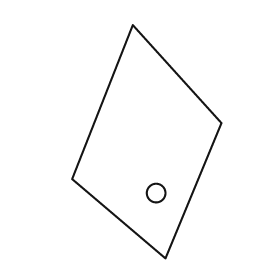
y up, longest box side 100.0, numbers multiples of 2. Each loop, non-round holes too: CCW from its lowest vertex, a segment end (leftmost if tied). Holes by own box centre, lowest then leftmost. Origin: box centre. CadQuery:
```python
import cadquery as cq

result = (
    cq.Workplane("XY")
    .moveTo(8.0, -50.0)
    .lineTo(32.0, 8.0)
    .lineTo(-6.0, 50.0)
    .lineTo(-32.0, -16.0)
    .close()
    .moveTo(4.0, -22.0)
    .circle(4.0)
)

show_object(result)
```